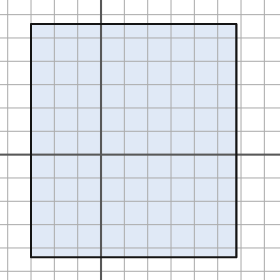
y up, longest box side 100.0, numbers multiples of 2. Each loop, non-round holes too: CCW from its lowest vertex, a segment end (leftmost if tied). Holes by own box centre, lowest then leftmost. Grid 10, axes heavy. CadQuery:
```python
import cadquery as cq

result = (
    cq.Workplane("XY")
    .moveTo(-30.0, -44.0)
    .lineTo(58.0, -44.0)
    .lineTo(58.0, 56.0)
    .lineTo(-30.0, 56.0)
    .close()
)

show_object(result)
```